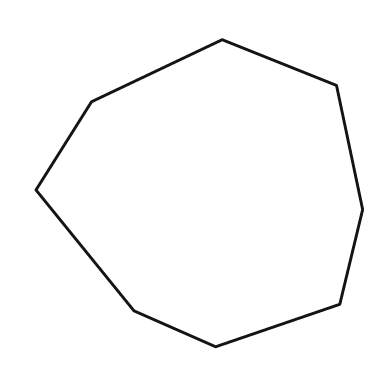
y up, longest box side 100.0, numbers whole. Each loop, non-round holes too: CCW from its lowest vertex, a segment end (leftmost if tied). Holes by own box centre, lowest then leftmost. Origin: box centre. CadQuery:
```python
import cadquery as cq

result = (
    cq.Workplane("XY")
    .moveTo(5.0, -47.0)
    .lineTo(43.0, -34.0)
    .lineTo(50.0, -5.0)
    .lineTo(42.0, 33.0)
    .lineTo(7.0, 47.0)
    .lineTo(-33.0, 28.0)
    .lineTo(-50.0, 1.0)
    .lineTo(-20.0, -36.0)
    .close()
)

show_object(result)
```